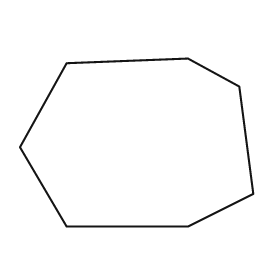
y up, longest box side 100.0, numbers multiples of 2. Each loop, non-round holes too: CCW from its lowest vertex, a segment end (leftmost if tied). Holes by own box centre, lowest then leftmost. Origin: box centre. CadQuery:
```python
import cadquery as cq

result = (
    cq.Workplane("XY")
    .moveTo(-30.0, -36.0)
    .lineTo(22.0, -36.0)
    .lineTo(50.0, -22.0)
    .lineTo(44.0, 24.0)
    .lineTo(22.0, 36.0)
    .lineTo(-30.0, 34.0)
    .lineTo(-50.0, -2.0)
    .close()
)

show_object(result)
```